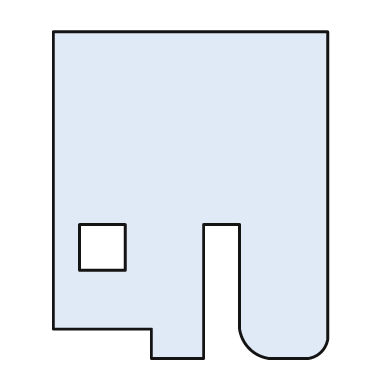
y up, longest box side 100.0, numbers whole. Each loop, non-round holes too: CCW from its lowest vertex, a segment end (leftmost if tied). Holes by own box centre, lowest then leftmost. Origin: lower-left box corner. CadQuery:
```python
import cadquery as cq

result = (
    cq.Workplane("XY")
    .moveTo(30.0, 0.0)
    .lineTo(46.0, 0.0)
    .lineTo(46.0, 41.0)
    .lineTo(57.0, 41.0)
    .lineTo(57.0, 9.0)
    .threePointArc((60.0, 3.0), (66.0, 0.0))
    .lineTo(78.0, 0.0)
    .threePointArc((82.0, 2.0), (84.0, 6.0))
    .lineTo(84.0, 100.0)
    .lineTo(0.0, 100.0)
    .lineTo(0.0, 9.0)
    .lineTo(30.0, 9.0)
    .close()
    .moveTo(8.0, 27.0)
    .lineTo(22.0, 27.0)
    .lineTo(22.0, 41.0)
    .lineTo(8.0, 41.0)
    .close()
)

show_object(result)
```